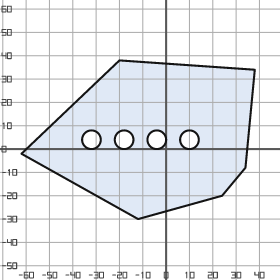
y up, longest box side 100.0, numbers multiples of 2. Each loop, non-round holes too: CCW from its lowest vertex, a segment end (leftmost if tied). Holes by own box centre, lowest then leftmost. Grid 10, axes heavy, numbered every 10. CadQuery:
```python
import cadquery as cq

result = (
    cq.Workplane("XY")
    .moveTo(-12.0, -30.0)
    .lineTo(24.0, -20.0)
    .lineTo(34.0, -8.0)
    .lineTo(38.0, 34.0)
    .lineTo(-20.0, 38.0)
    .lineTo(-62.0, -2.0)
    .close()
    .moveTo(-32.0, 4.0)
    .circle(4.0)
    .moveTo(-18.0, 4.0)
    .circle(4.0)
    .moveTo(-4.0, 4.0)
    .circle(4.0)
    .moveTo(10.0, 4.0)
    .circle(4.0)
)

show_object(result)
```